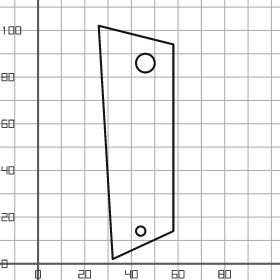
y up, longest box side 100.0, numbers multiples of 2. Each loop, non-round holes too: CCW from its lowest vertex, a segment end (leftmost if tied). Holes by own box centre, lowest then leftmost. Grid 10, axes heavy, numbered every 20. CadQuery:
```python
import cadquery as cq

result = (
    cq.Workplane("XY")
    .moveTo(32.0, 2.0)
    .lineTo(58.0, 14.0)
    .lineTo(58.0, 94.0)
    .lineTo(26.0, 102.0)
    .close()
    .moveTo(44.0, 14.0)
    .circle(2.0)
    .moveTo(46.0, 86.0)
    .circle(4.0)
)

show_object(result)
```